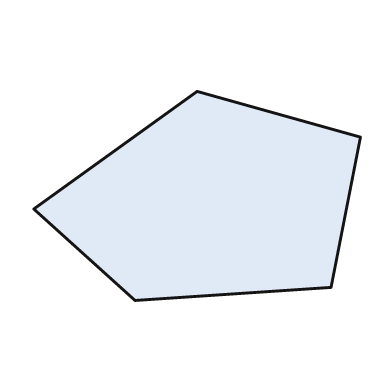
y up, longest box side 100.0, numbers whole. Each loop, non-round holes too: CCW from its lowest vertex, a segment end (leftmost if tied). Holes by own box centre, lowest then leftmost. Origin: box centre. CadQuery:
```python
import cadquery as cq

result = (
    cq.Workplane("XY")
    .moveTo(-19.0, -32.0)
    .lineTo(41.0, -28.0)
    .lineTo(50.0, 18.0)
    .lineTo(0.0, 32.0)
    .lineTo(-50.0, -4.0)
    .close()
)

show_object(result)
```